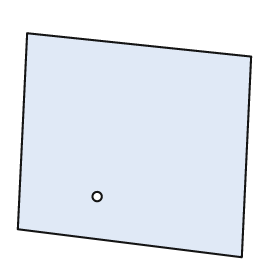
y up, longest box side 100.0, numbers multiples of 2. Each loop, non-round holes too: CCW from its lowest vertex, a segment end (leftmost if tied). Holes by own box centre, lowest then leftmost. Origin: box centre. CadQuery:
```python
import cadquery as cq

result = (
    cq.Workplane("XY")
    .moveTo(46.0, -48.0)
    .lineTo(50.0, 38.0)
    .lineTo(-46.0, 48.0)
    .lineTo(-50.0, -36.0)
    .close()
    .moveTo(-16.0, -22.0)
    .circle(2.0)
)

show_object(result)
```